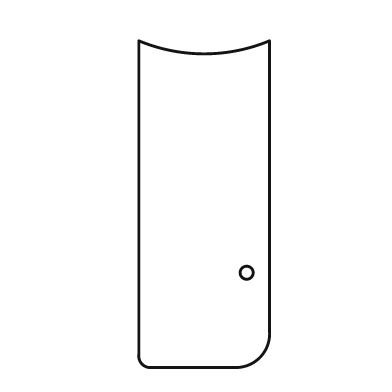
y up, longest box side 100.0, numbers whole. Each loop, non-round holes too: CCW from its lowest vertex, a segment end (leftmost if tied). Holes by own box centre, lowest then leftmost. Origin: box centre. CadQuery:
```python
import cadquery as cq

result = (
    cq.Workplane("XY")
    .moveTo(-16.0, -50.0)
    .lineTo(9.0, -50.0)
    .threePointArc((17.0, -47.0), (20.0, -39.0))
    .lineTo(20.0, 50.0)
    .threePointArc((0.0, 46.0), (-20.0, 50.0))
    .lineTo(-20.0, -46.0)
    .threePointArc((-19.0, -49.0), (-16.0, -50.0))
    .close()
    .moveTo(13.0, -21.0)
    .circle(2.0)
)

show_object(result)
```